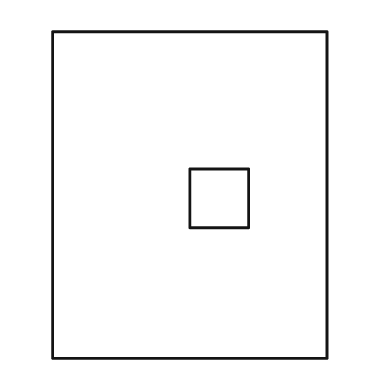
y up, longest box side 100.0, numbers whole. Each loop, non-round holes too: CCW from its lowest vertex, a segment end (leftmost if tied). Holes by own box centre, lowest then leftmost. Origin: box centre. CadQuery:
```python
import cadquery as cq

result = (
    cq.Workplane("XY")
    .moveTo(-42.0, -50.0)
    .lineTo(42.0, -50.0)
    .lineTo(42.0, 50.0)
    .lineTo(-42.0, 50.0)
    .close()
    .moveTo(0.0, -10.0)
    .lineTo(18.0, -10.0)
    .lineTo(18.0, 8.0)
    .lineTo(0.0, 8.0)
    .close()
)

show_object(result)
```